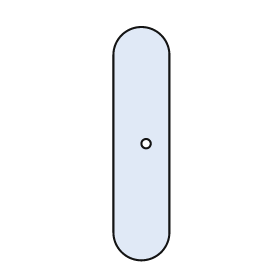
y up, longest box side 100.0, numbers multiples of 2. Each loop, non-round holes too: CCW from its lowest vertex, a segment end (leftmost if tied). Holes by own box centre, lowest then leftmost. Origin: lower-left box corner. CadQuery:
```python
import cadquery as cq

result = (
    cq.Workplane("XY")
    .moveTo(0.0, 12.0)
    .threePointArc((12.0, 0.0), (24.0, 12.0))
    .lineTo(24.0, 88.0)
    .threePointArc((12.0, 100.0), (0.0, 88.0))
    .close()
    .moveTo(14.0, 50.0)
    .circle(2.0)
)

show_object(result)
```